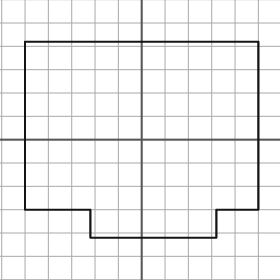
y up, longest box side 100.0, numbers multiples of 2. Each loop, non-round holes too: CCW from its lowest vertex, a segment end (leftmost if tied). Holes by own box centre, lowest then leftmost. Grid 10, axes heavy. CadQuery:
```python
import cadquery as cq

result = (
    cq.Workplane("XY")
    .moveTo(-22.0, -42.0)
    .lineTo(32.0, -42.0)
    .lineTo(32.0, -30.0)
    .lineTo(50.0, -30.0)
    .lineTo(50.0, 42.0)
    .lineTo(-50.0, 42.0)
    .lineTo(-50.0, -30.0)
    .lineTo(-22.0, -30.0)
    .close()
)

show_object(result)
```